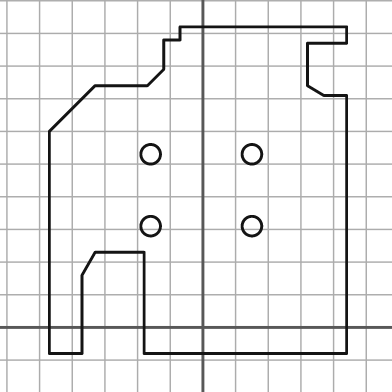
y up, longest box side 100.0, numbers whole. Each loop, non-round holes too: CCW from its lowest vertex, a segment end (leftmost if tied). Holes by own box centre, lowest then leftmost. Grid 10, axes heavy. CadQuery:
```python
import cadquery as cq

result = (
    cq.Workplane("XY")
    .moveTo(-47.0, -8.0)
    .lineTo(-37.0, -8.0)
    .lineTo(-37.0, 16.0)
    .lineTo(-33.0, 23.0)
    .lineTo(-18.0, 23.0)
    .lineTo(-18.0, -8.0)
    .lineTo(44.0, -8.0)
    .lineTo(44.0, 71.0)
    .lineTo(37.0, 71.0)
    .lineTo(32.0, 74.0)
    .lineTo(32.0, 87.0)
    .lineTo(44.0, 87.0)
    .lineTo(44.0, 92.0)
    .lineTo(-7.0, 92.0)
    .lineTo(-7.0, 88.0)
    .lineTo(-12.0, 88.0)
    .lineTo(-12.0, 79.0)
    .lineTo(-17.0, 74.0)
    .lineTo(-33.0, 74.0)
    .lineTo(-47.0, 60.0)
    .close()
    .moveTo(-16.0, 31.0)
    .circle(3.0)
    .moveTo(15.0, 31.0)
    .circle(3.0)
    .moveTo(-16.0, 53.0)
    .circle(3.0)
    .moveTo(15.0, 53.0)
    .circle(3.0)
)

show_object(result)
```